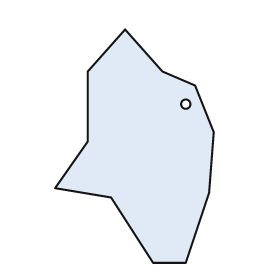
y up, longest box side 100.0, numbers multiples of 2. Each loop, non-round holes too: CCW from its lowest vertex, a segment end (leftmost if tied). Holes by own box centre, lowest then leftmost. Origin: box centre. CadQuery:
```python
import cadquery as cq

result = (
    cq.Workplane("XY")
    .moveTo(8.0, -50.0)
    .lineTo(22.0, -50.0)
    .lineTo(32.0, -20.0)
    .lineTo(34.0, 6.0)
    .lineTo(26.0, 26.0)
    .lineTo(12.0, 32.0)
    .lineTo(-4.0, 50.0)
    .lineTo(-20.0, 32.0)
    .lineTo(-20.0, 2.0)
    .lineTo(-34.0, -18.0)
    .lineTo(-10.0, -22.0)
    .close()
    .moveTo(22.0, 18.0)
    .circle(2.0)
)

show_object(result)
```